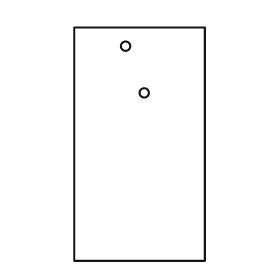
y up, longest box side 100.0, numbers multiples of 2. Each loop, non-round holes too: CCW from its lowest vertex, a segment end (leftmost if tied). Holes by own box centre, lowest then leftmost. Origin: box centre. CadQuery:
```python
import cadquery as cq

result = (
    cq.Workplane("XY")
    .moveTo(-28.0, -50.0)
    .lineTo(28.0, -50.0)
    .lineTo(28.0, 50.0)
    .lineTo(-28.0, 50.0)
    .close()
    .moveTo(2.0, 22.0)
    .circle(2.0)
    .moveTo(-6.0, 42.0)
    .circle(2.0)
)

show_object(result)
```